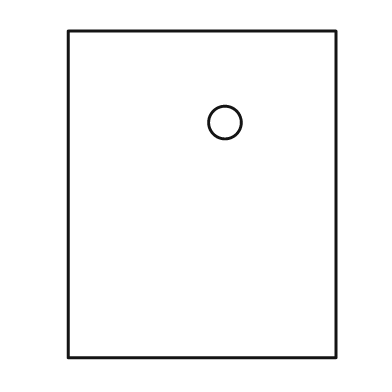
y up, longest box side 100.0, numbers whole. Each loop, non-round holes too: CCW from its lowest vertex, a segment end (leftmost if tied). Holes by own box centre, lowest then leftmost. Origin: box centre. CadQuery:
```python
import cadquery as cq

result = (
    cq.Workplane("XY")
    .moveTo(-41.0, -50.0)
    .lineTo(41.0, -50.0)
    .lineTo(41.0, 50.0)
    .lineTo(-41.0, 50.0)
    .close()
    .moveTo(7.0, 22.0)
    .circle(5.0)
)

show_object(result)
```